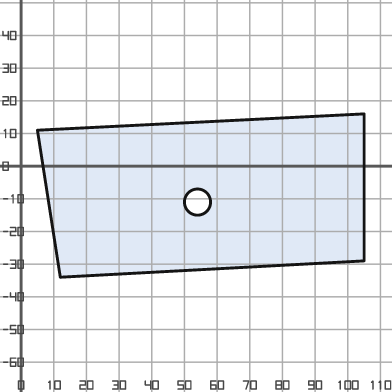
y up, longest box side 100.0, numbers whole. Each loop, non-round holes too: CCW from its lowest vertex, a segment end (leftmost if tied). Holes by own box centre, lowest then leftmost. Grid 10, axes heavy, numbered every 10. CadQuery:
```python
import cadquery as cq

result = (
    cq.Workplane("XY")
    .moveTo(12.0, -34.0)
    .lineTo(105.0, -29.0)
    .lineTo(105.0, 16.0)
    .lineTo(5.0, 11.0)
    .close()
    .moveTo(54.0, -11.0)
    .circle(4.0)
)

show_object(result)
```